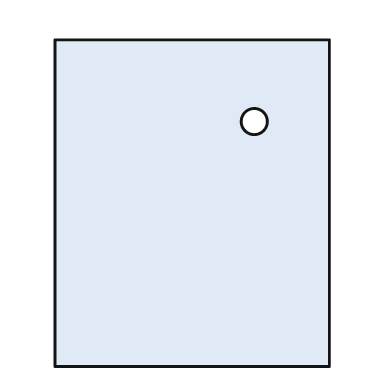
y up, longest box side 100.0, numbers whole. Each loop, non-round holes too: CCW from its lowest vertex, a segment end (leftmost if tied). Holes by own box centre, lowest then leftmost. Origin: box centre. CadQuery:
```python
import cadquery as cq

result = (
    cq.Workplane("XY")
    .moveTo(-42.0, -50.0)
    .lineTo(42.0, -50.0)
    .lineTo(42.0, 50.0)
    .lineTo(-42.0, 50.0)
    .close()
    .moveTo(19.0, 25.0)
    .circle(4.0)
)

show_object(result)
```